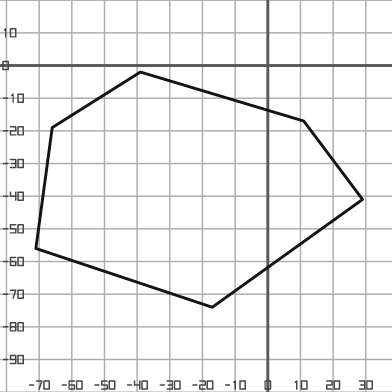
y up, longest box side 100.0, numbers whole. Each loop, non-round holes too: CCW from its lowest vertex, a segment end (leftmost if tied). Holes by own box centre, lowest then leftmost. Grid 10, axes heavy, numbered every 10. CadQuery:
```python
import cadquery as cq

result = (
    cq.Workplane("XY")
    .moveTo(-17.0, -74.0)
    .lineTo(29.0, -41.0)
    .lineTo(11.0, -17.0)
    .lineTo(-39.0, -2.0)
    .lineTo(-66.0, -19.0)
    .lineTo(-71.0, -56.0)
    .close()
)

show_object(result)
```